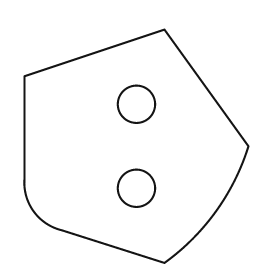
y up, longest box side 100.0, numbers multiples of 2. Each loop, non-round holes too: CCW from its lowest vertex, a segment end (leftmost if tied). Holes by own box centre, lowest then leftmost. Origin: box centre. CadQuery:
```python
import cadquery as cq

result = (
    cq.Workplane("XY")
    .moveTo(12.0, -50.0)
    .threePointArc((34.0, -28.0), (48.0, 0.0))
    .lineTo(12.0, 50.0)
    .lineTo(-48.0, 30.0)
    .lineTo(-48.0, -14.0)
    .threePointArc((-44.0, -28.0), (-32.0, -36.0))
    .close()
    .moveTo(0.0, -18.0)
    .circle(8.0)
    .moveTo(0.0, 18.0)
    .circle(8.0)
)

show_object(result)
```